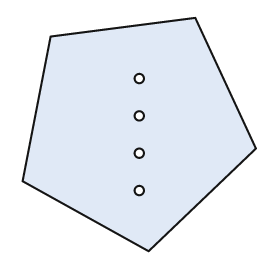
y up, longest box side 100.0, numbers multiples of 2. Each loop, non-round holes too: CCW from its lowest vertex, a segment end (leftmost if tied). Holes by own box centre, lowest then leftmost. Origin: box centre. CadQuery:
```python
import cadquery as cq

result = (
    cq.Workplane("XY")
    .moveTo(4.0, -50.0)
    .lineTo(50.0, -6.0)
    .lineTo(24.0, 50.0)
    .lineTo(-38.0, 42.0)
    .lineTo(-50.0, -20.0)
    .close()
    .moveTo(0.0, -24.0)
    .circle(2.0)
    .moveTo(0.0, -8.0)
    .circle(2.0)
    .moveTo(0.0, 8.0)
    .circle(2.0)
    .moveTo(0.0, 24.0)
    .circle(2.0)
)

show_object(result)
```